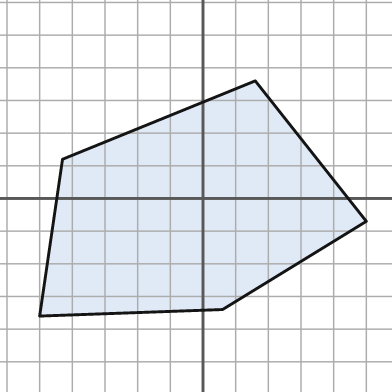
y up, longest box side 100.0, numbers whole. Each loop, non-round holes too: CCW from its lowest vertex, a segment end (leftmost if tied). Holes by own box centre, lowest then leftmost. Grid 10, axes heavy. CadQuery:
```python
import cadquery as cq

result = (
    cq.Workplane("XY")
    .moveTo(-50.0, -36.0)
    .lineTo(6.0, -34.0)
    .lineTo(50.0, -7.0)
    .lineTo(16.0, 36.0)
    .lineTo(-43.0, 12.0)
    .close()
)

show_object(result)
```